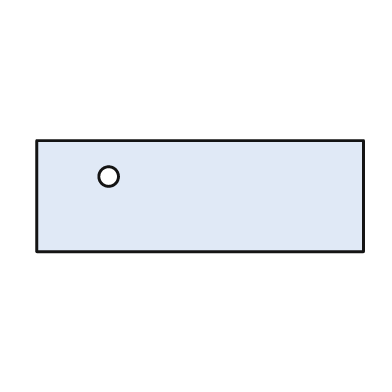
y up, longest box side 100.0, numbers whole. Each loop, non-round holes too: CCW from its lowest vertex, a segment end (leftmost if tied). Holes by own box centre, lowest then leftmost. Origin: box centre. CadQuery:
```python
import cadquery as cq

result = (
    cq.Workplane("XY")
    .moveTo(-50.0, -17.0)
    .lineTo(50.0, -17.0)
    .lineTo(50.0, 17.0)
    .lineTo(-50.0, 17.0)
    .close()
    .moveTo(-28.0, 6.0)
    .circle(3.0)
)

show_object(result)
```